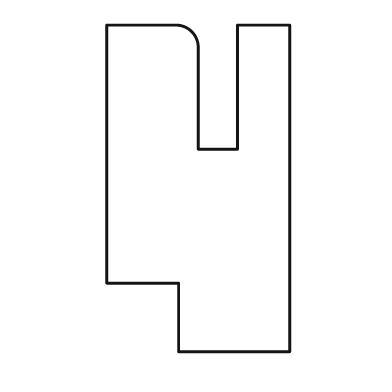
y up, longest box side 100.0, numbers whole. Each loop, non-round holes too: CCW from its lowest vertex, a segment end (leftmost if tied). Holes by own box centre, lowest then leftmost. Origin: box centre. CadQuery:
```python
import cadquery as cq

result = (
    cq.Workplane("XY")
    .moveTo(-6.0, -50.0)
    .lineTo(28.0, -50.0)
    .lineTo(28.0, 50.0)
    .lineTo(12.0, 50.0)
    .lineTo(12.0, 12.0)
    .lineTo(0.0, 12.0)
    .lineTo(0.0, 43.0)
    .threePointArc((-2.0, 48.0), (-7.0, 50.0))
    .lineTo(-28.0, 50.0)
    .lineTo(-28.0, -29.0)
    .lineTo(-6.0, -29.0)
    .close()
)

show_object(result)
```